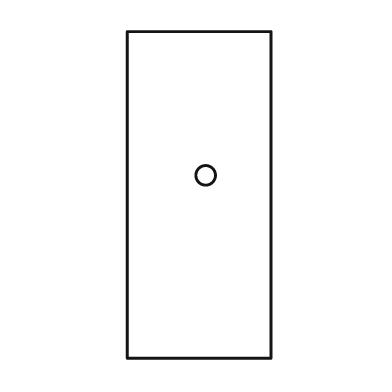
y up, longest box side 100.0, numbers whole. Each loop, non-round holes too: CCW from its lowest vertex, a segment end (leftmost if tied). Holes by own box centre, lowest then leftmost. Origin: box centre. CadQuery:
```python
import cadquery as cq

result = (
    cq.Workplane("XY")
    .moveTo(-22.0, -50.0)
    .lineTo(22.0, -50.0)
    .lineTo(22.0, 50.0)
    .lineTo(-22.0, 50.0)
    .close()
    .moveTo(2.0, 6.0)
    .circle(3.0)
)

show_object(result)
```